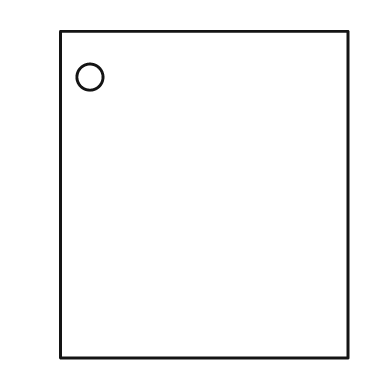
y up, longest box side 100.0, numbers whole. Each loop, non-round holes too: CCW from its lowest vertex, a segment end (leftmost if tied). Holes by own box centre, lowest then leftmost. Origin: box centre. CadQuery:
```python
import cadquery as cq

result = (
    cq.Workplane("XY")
    .moveTo(-44.0, -50.0)
    .lineTo(44.0, -50.0)
    .lineTo(44.0, 50.0)
    .lineTo(-44.0, 50.0)
    .close()
    .moveTo(-35.0, 36.0)
    .circle(4.0)
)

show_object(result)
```